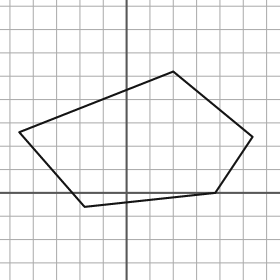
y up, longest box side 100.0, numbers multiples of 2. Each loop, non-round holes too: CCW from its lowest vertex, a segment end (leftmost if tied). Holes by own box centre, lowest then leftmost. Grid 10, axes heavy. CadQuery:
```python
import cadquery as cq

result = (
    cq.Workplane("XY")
    .moveTo(-18.0, -6.0)
    .lineTo(38.0, 0.0)
    .lineTo(54.0, 24.0)
    .lineTo(20.0, 52.0)
    .lineTo(-46.0, 26.0)
    .close()
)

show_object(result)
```